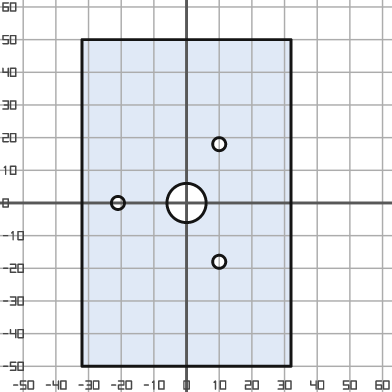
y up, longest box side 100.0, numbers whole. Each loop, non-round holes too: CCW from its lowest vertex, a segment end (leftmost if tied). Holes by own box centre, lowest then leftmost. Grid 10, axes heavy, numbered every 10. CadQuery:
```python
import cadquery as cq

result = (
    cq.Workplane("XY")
    .moveTo(-32.0, -50.0)
    .lineTo(32.0, -50.0)
    .lineTo(32.0, 50.0)
    .lineTo(-32.0, 50.0)
    .close()
    .moveTo(10.0, -18.0)
    .circle(2.0)
    .moveTo(-21.0, 0.0)
    .circle(2.0)
    .moveTo(0.0, 0.0)
    .circle(6.0)
    .moveTo(10.0, 18.0)
    .circle(2.0)
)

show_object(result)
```